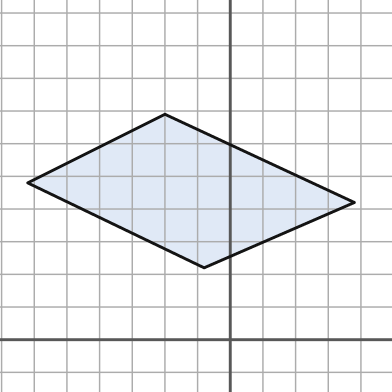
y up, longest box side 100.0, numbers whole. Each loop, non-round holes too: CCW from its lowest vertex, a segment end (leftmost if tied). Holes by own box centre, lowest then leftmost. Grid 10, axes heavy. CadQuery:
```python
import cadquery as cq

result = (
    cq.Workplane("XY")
    .moveTo(-8.0, 22.0)
    .lineTo(38.0, 42.0)
    .lineTo(-20.0, 69.0)
    .lineTo(-62.0, 48.0)
    .close()
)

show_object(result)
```